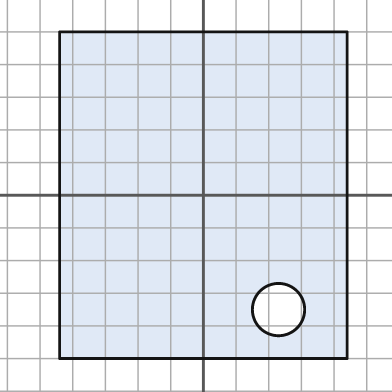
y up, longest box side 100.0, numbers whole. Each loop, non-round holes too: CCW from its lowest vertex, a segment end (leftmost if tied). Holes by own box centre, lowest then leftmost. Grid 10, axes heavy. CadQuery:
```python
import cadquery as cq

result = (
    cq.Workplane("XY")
    .moveTo(-44.0, -50.0)
    .lineTo(44.0, -50.0)
    .lineTo(44.0, 50.0)
    .lineTo(-44.0, 50.0)
    .close()
    .moveTo(23.0, -35.0)
    .circle(8.0)
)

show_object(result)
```